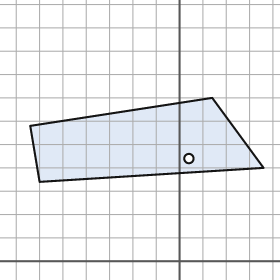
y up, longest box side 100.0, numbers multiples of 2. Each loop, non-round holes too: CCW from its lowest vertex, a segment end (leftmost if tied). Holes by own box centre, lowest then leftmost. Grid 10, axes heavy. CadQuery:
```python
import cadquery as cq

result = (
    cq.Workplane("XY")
    .moveTo(-60.0, 34.0)
    .lineTo(36.0, 40.0)
    .lineTo(14.0, 70.0)
    .lineTo(-64.0, 58.0)
    .close()
    .moveTo(4.0, 44.0)
    .circle(2.0)
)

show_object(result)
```